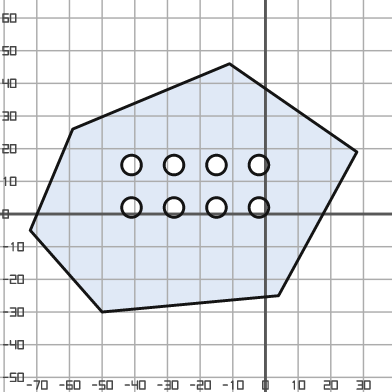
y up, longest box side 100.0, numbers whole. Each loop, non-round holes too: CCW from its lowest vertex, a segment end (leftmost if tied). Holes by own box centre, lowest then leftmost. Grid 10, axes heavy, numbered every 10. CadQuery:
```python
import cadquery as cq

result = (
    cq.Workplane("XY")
    .moveTo(-50.0, -30.0)
    .lineTo(4.0, -25.0)
    .lineTo(28.0, 19.0)
    .lineTo(-11.0, 46.0)
    .lineTo(-59.0, 26.0)
    .lineTo(-72.0, -5.0)
    .close()
    .moveTo(-41.0, 2.0)
    .circle(3.0)
    .moveTo(-28.0, 2.0)
    .circle(3.0)
    .moveTo(-15.0, 2.0)
    .circle(3.0)
    .moveTo(-2.0, 2.0)
    .circle(3.0)
    .moveTo(-41.0, 15.0)
    .circle(3.0)
    .moveTo(-28.0, 15.0)
    .circle(3.0)
    .moveTo(-15.0, 15.0)
    .circle(3.0)
    .moveTo(-2.0, 15.0)
    .circle(3.0)
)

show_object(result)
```